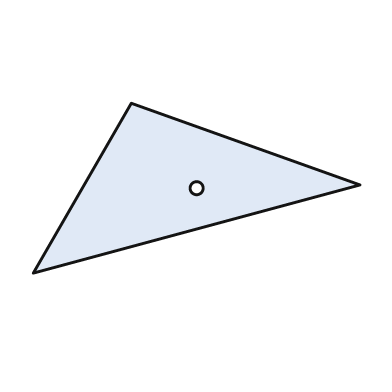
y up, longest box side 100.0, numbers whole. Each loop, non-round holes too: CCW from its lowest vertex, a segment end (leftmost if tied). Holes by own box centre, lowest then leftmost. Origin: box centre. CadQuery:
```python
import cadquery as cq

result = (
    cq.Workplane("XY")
    .moveTo(-50.0, -26.0)
    .lineTo(50.0, 1.0)
    .lineTo(-20.0, 26.0)
    .close()
    .moveTo(0.0, 0.0)
    .circle(2.0)
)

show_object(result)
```